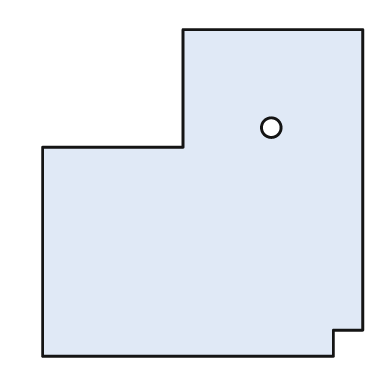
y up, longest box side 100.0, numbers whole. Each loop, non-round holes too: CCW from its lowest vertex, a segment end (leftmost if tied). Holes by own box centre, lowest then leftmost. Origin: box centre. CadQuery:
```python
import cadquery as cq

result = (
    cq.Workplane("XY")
    .moveTo(-49.0, -50.0)
    .lineTo(40.0, -50.0)
    .lineTo(40.0, -42.0)
    .lineTo(49.0, -42.0)
    .lineTo(49.0, 50.0)
    .lineTo(-6.0, 50.0)
    .lineTo(-6.0, 14.0)
    .lineTo(-49.0, 14.0)
    .close()
    .moveTo(21.0, 20.0)
    .circle(3.0)
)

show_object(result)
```